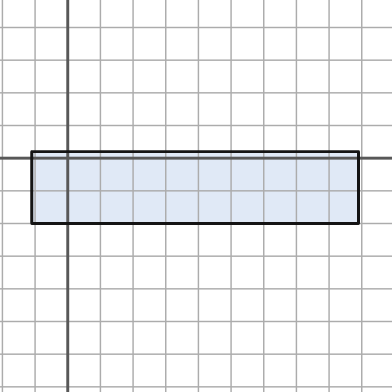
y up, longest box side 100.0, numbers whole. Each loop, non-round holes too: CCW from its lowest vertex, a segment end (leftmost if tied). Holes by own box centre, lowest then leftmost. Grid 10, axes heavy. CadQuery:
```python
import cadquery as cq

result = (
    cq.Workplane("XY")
    .moveTo(-11.0, -20.0)
    .lineTo(89.0, -20.0)
    .lineTo(89.0, 2.0)
    .lineTo(-11.0, 2.0)
    .close()
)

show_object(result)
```